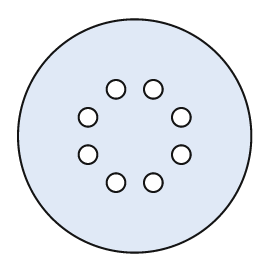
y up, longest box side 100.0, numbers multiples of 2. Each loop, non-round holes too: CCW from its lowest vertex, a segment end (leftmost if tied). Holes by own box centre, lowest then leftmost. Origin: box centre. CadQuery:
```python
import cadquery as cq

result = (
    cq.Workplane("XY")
    .moveTo(0.0, 0.0)
    .circle(50.0)
    .moveTo(-8.0, -20.0)
    .circle(4.0)
    .moveTo(8.0, -20.0)
    .circle(4.0)
    .moveTo(-20.0, -8.0)
    .circle(4.0)
    .moveTo(20.0, -8.0)
    .circle(4.0)
    .moveTo(-20.0, 8.0)
    .circle(4.0)
    .moveTo(20.0, 8.0)
    .circle(4.0)
    .moveTo(-8.0, 20.0)
    .circle(4.0)
    .moveTo(8.0, 20.0)
    .circle(4.0)
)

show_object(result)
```